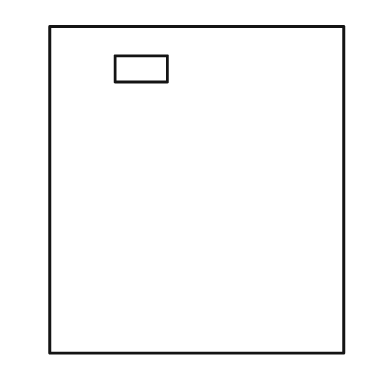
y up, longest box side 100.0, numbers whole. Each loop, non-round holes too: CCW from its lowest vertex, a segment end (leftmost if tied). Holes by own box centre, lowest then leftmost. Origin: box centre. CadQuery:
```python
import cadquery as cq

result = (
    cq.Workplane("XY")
    .moveTo(-45.0, -50.0)
    .lineTo(45.0, -50.0)
    .lineTo(45.0, 50.0)
    .lineTo(-45.0, 50.0)
    .close()
    .moveTo(-25.0, 33.0)
    .lineTo(-9.0, 33.0)
    .lineTo(-9.0, 41.0)
    .lineTo(-25.0, 41.0)
    .close()
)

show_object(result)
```